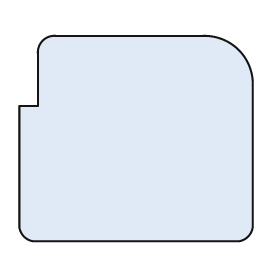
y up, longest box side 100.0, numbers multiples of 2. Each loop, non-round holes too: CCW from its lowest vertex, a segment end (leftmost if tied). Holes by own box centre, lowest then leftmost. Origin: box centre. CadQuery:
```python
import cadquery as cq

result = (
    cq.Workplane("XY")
    .moveTo(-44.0, -44.0)
    .lineTo(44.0, -44.0)
    .threePointArc((48.0, -42.0), (50.0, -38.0))
    .lineTo(50.0, 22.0)
    .threePointArc((44.0, 38.0), (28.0, 44.0))
    .lineTo(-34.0, 44.0)
    .threePointArc((-40.0, 42.0), (-42.0, 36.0))
    .lineTo(-42.0, 14.0)
    .lineTo(-50.0, 14.0)
    .lineTo(-50.0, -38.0)
    .threePointArc((-48.0, -42.0), (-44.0, -44.0))
    .close()
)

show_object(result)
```